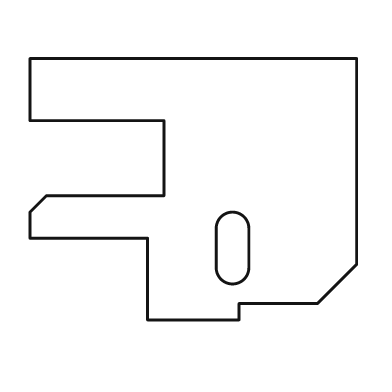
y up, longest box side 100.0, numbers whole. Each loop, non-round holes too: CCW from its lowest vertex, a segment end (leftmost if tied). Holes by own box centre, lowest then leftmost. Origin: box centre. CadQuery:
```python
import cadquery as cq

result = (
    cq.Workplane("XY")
    .moveTo(-14.0, -40.0)
    .lineTo(14.0, -40.0)
    .lineTo(14.0, -35.0)
    .lineTo(38.0, -35.0)
    .lineTo(50.0, -23.0)
    .lineTo(50.0, 40.0)
    .lineTo(-50.0, 40.0)
    .lineTo(-50.0, 21.0)
    .lineTo(-9.0, 21.0)
    .lineTo(-9.0, -2.0)
    .lineTo(-45.0, -2.0)
    .lineTo(-50.0, -7.0)
    .lineTo(-50.0, -15.0)
    .lineTo(-14.0, -15.0)
    .close()
    .moveTo(7.0, -24.0)
    .threePointArc((12.0, -29.0), (17.0, -24.0))
    .lineTo(17.0, -12.0)
    .threePointArc((12.0, -7.0), (7.0, -12.0))
    .close()
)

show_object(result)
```